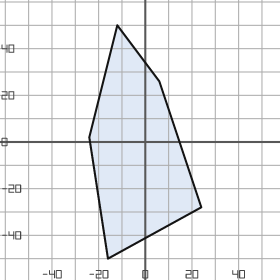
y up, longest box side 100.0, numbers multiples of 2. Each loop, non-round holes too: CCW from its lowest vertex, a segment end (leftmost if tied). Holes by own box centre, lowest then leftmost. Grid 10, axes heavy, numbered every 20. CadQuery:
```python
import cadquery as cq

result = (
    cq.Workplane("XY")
    .moveTo(-16.0, -50.0)
    .lineTo(24.0, -28.0)
    .lineTo(6.0, 26.0)
    .lineTo(-12.0, 50.0)
    .lineTo(-24.0, 2.0)
    .close()
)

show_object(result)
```